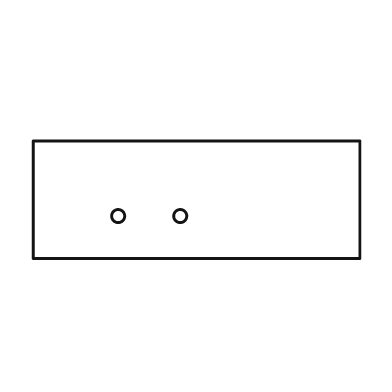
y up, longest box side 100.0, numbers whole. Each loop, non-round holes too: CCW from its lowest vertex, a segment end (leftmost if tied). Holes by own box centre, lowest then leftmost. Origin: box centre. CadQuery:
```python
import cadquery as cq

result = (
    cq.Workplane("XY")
    .moveTo(-50.0, -18.0)
    .lineTo(50.0, -18.0)
    .lineTo(50.0, 18.0)
    .lineTo(-50.0, 18.0)
    .close()
    .moveTo(-24.0, -5.0)
    .circle(2.0)
    .moveTo(-5.0, -5.0)
    .circle(2.0)
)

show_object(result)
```